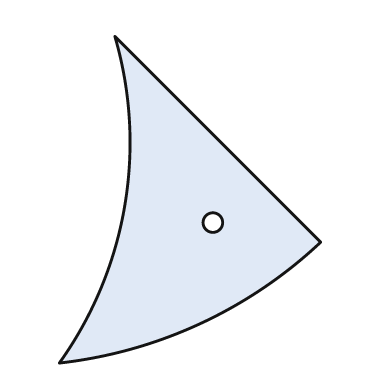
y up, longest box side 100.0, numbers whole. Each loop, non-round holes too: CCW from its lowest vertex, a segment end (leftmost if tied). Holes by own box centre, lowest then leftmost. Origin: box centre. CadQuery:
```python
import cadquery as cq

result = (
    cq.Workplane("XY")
    .moveTo(-40.0, -50.0)
    .threePointArc((3.0, -38.0), (40.0, -13.0))
    .lineTo(-23.0, 50.0)
    .threePointArc((-20.0, -2.0), (-40.0, -50.0))
    .close()
    .moveTo(7.0, -7.0)
    .circle(3.0)
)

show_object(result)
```